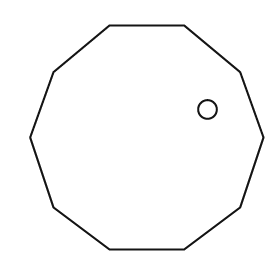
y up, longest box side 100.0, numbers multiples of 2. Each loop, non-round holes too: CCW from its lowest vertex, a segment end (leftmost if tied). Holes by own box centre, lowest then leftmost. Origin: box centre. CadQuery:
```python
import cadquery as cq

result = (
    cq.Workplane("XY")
    .moveTo(-16.0, -48.0)
    .lineTo(16.0, -48.0)
    .lineTo(40.0, -30.0)
    .lineTo(50.0, 0.0)
    .lineTo(40.0, 28.0)
    .lineTo(16.0, 48.0)
    .lineTo(-16.0, 48.0)
    .lineTo(-40.0, 28.0)
    .lineTo(-50.0, 0.0)
    .lineTo(-40.0, -30.0)
    .close()
    .moveTo(26.0, 12.0)
    .circle(4.0)
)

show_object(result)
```